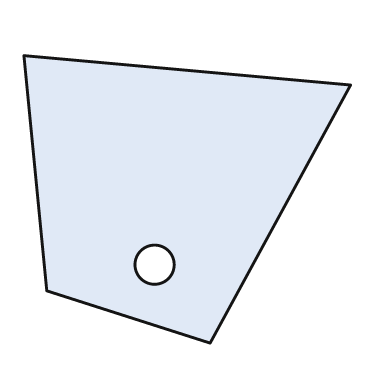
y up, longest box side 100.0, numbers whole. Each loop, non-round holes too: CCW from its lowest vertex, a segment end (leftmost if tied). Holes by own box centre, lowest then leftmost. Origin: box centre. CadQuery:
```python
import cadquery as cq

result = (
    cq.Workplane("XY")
    .moveTo(7.0, -44.0)
    .lineTo(50.0, 35.0)
    .lineTo(-50.0, 44.0)
    .lineTo(-43.0, -28.0)
    .close()
    .moveTo(-10.0, -20.0)
    .circle(6.0)
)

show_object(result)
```